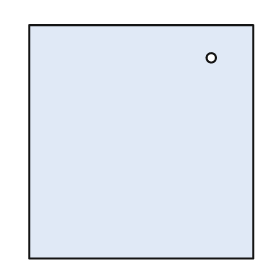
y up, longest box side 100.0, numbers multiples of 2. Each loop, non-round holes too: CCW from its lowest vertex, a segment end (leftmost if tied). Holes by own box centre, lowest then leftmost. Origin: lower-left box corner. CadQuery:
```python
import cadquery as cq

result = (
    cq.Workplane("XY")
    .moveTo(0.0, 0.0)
    .lineTo(96.0, 0.0)
    .lineTo(96.0, 100.0)
    .lineTo(0.0, 100.0)
    .close()
    .moveTo(78.0, 86.0)
    .circle(2.0)
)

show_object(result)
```